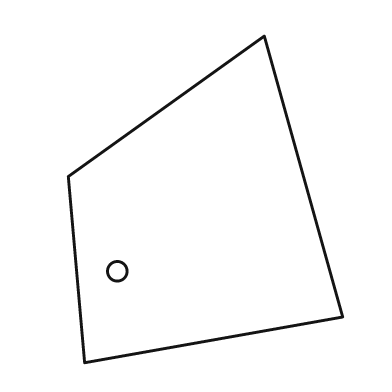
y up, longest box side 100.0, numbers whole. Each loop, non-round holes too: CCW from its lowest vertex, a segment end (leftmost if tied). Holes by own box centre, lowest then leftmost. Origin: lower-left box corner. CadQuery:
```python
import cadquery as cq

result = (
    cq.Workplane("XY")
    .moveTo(5.0, 0.0)
    .lineTo(84.0, 14.0)
    .lineTo(60.0, 100.0)
    .lineTo(0.0, 57.0)
    .close()
    .moveTo(15.0, 28.0)
    .circle(3.0)
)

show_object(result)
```